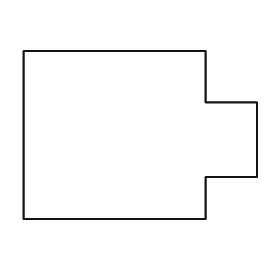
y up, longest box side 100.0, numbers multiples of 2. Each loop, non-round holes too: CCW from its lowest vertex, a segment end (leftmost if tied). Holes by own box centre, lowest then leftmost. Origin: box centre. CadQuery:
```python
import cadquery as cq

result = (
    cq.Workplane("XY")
    .moveTo(-50.0, -36.0)
    .lineTo(28.0, -36.0)
    .lineTo(28.0, -18.0)
    .lineTo(50.0, -18.0)
    .lineTo(50.0, 14.0)
    .lineTo(28.0, 14.0)
    .lineTo(28.0, 36.0)
    .lineTo(-50.0, 36.0)
    .close()
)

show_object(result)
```